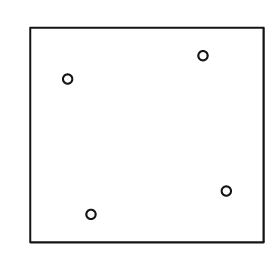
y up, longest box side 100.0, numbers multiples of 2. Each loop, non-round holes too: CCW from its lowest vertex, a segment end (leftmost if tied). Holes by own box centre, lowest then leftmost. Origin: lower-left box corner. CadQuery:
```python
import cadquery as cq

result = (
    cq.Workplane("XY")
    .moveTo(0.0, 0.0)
    .lineTo(100.0, 0.0)
    .lineTo(100.0, 92.0)
    .lineTo(0.0, 92.0)
    .close()
    .moveTo(26.0, 12.0)
    .circle(2.0)
    .moveTo(84.0, 22.0)
    .circle(2.0)
    .moveTo(16.0, 70.0)
    .circle(2.0)
    .moveTo(74.0, 80.0)
    .circle(2.0)
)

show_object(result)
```